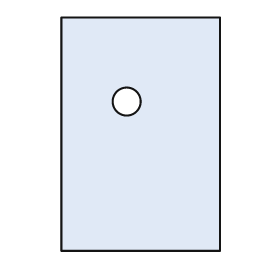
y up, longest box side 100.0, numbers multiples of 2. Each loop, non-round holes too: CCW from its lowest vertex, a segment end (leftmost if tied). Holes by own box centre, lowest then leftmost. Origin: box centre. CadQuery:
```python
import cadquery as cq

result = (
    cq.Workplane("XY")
    .moveTo(-34.0, -50.0)
    .lineTo(34.0, -50.0)
    .lineTo(34.0, 50.0)
    .lineTo(-34.0, 50.0)
    .close()
    .moveTo(-6.0, 14.0)
    .circle(6.0)
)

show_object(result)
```